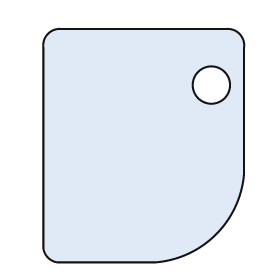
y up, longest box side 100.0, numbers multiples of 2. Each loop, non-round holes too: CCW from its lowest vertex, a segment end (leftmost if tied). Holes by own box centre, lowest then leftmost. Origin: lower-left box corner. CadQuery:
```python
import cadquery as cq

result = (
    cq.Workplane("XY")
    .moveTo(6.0, 0.0)
    .lineTo(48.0, 0.0)
    .threePointArc((74.0, 12.0), (86.0, 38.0))
    .lineTo(86.0, 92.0)
    .threePointArc((84.0, 98.0), (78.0, 100.0))
    .lineTo(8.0, 100.0)
    .threePointArc((2.0, 98.0), (0.0, 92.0))
    .lineTo(0.0, 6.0)
    .threePointArc((2.0, 2.0), (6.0, 0.0))
    .close()
    .moveTo(72.0, 76.0)
    .circle(8.0)
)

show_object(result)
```